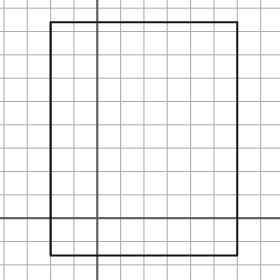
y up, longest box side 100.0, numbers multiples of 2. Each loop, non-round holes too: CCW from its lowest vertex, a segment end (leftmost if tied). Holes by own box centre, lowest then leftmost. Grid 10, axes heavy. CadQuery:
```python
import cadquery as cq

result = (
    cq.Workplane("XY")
    .moveTo(-20.0, -16.0)
    .lineTo(60.0, -16.0)
    .lineTo(60.0, 84.0)
    .lineTo(-20.0, 84.0)
    .close()
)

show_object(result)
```